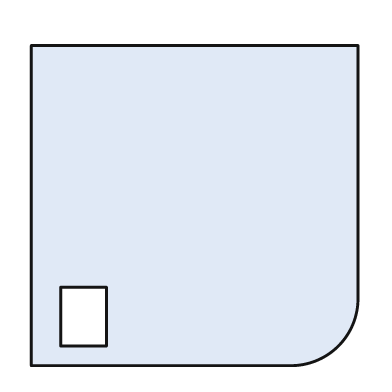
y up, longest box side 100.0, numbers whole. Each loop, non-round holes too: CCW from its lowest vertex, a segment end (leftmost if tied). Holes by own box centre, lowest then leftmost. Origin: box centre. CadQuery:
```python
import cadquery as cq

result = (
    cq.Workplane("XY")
    .moveTo(-50.0, -49.0)
    .lineTo(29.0, -49.0)
    .threePointArc((44.0, -43.0), (50.0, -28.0))
    .lineTo(50.0, 49.0)
    .lineTo(-50.0, 49.0)
    .close()
    .moveTo(-41.0, -43.0)
    .lineTo(-27.0, -43.0)
    .lineTo(-27.0, -25.0)
    .lineTo(-41.0, -25.0)
    .close()
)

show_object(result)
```